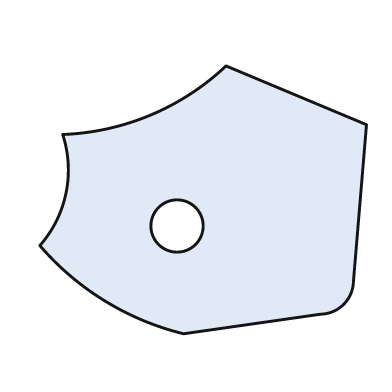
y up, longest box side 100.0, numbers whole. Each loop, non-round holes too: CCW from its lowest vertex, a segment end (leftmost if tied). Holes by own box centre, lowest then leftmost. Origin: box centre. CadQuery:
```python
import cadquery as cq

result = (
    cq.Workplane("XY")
    .moveTo(-6.0, -41.0)
    .lineTo(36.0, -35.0)
    .threePointArc((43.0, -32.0), (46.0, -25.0))
    .lineTo(50.0, 23.0)
    .lineTo(7.0, 41.0)
    .threePointArc((-16.0, 26.0), (-43.0, 20.0))
    .threePointArc((-42.0, 2.0), (-50.0, -14.0))
    .threePointArc((-30.0, -31.0), (-6.0, -41.0))
    .close()
    .moveTo(-8.0, -8.0)
    .circle(8.0)
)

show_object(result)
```